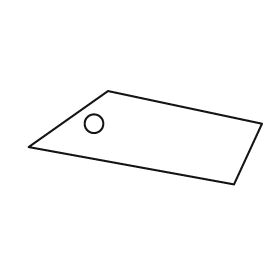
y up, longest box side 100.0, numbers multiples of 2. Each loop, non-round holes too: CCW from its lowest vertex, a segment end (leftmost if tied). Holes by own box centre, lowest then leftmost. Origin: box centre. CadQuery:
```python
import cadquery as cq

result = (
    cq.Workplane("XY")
    .moveTo(38.0, -20.0)
    .lineTo(50.0, 6.0)
    .lineTo(-16.0, 20.0)
    .lineTo(-50.0, -4.0)
    .close()
    .moveTo(-22.0, 6.0)
    .circle(4.0)
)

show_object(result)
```